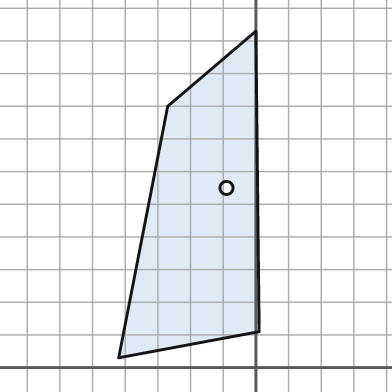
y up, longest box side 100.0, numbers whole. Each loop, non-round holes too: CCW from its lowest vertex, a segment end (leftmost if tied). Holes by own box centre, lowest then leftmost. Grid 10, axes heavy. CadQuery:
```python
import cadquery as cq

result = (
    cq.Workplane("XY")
    .moveTo(-42.0, 3.0)
    .lineTo(1.0, 11.0)
    .lineTo(0.0, 103.0)
    .lineTo(-27.0, 80.0)
    .close()
    .moveTo(-9.0, 55.0)
    .circle(2.0)
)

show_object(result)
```